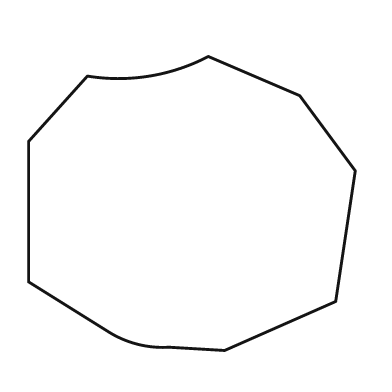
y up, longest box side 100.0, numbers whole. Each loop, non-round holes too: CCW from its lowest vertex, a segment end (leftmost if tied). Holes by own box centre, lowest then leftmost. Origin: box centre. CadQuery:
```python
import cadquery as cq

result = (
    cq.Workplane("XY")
    .moveTo(10.0, -45.0)
    .lineTo(44.0, -30.0)
    .lineTo(50.0, 10.0)
    .lineTo(33.0, 33.0)
    .lineTo(5.0, 45.0)
    .threePointArc((-13.0, 39.0), (-32.0, 39.0))
    .lineTo(-50.0, 19.0)
    .lineTo(-50.0, -24.0)
    .lineTo(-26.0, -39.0)
    .threePointArc((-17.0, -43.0), (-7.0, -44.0))
    .close()
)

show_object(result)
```